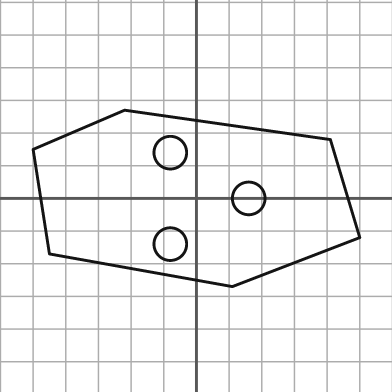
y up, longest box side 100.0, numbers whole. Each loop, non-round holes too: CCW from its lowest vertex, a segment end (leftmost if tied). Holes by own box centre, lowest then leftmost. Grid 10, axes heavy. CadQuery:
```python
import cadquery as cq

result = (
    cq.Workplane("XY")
    .moveTo(11.0, -27.0)
    .lineTo(50.0, -12.0)
    .lineTo(41.0, 18.0)
    .lineTo(-22.0, 27.0)
    .lineTo(-50.0, 15.0)
    .lineTo(-45.0, -17.0)
    .close()
    .moveTo(-8.0, -14.0)
    .circle(5.0)
    .moveTo(16.0, 0.0)
    .circle(5.0)
    .moveTo(-8.0, 14.0)
    .circle(5.0)
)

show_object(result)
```